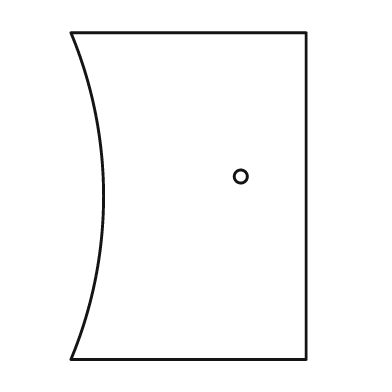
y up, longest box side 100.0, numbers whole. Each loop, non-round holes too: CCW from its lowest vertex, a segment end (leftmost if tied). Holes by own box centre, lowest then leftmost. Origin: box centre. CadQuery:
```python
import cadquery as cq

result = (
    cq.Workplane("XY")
    .moveTo(-36.0, -50.0)
    .lineTo(36.0, -50.0)
    .lineTo(36.0, 50.0)
    .lineTo(-36.0, 50.0)
    .threePointArc((-26.0, 0.0), (-36.0, -50.0))
    .close()
    .moveTo(16.0, 6.0)
    .circle(2.0)
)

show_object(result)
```